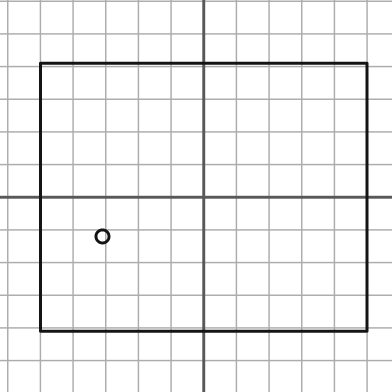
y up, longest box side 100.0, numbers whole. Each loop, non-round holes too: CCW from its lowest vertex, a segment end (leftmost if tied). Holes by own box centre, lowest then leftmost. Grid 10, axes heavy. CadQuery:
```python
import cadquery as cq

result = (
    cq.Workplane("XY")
    .moveTo(-50.0, -41.0)
    .lineTo(50.0, -41.0)
    .lineTo(50.0, 41.0)
    .lineTo(-50.0, 41.0)
    .close()
    .moveTo(-31.0, -12.0)
    .circle(2.0)
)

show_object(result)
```